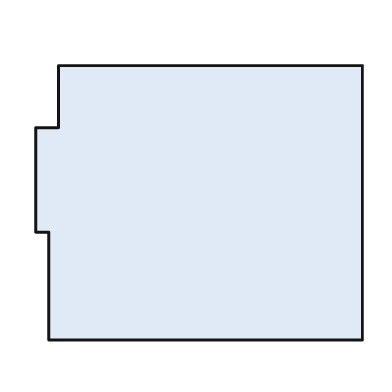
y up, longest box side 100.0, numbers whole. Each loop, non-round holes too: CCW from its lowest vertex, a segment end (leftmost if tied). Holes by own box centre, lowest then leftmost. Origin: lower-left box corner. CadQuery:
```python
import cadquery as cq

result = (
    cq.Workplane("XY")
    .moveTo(4.0, 0.0)
    .lineTo(100.0, 0.0)
    .lineTo(100.0, 84.0)
    .lineTo(7.0, 84.0)
    .lineTo(7.0, 65.0)
    .lineTo(0.0, 65.0)
    .lineTo(0.0, 33.0)
    .lineTo(4.0, 33.0)
    .close()
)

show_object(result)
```